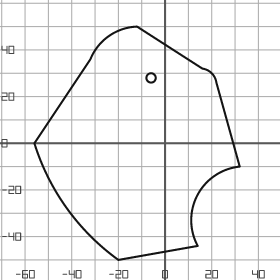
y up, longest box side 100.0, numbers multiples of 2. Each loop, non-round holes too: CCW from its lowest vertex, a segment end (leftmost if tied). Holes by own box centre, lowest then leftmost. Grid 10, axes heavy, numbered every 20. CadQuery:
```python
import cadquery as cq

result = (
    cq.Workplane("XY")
    .moveTo(-20.0, -50.0)
    .lineTo(14.0, -44.0)
    .threePointArc((14.0, -22.0), (32.0, -10.0))
    .lineTo(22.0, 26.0)
    .threePointArc((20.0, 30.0), (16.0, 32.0))
    .lineTo(-12.0, 50.0)
    .threePointArc((-24.0, 46.0), (-32.0, 36.0))
    .lineTo(-56.0, 0.0)
    .threePointArc((-42.0, -28.0), (-20.0, -50.0))
    .close()
    .moveTo(-6.0, 28.0)
    .circle(2.0)
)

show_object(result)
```